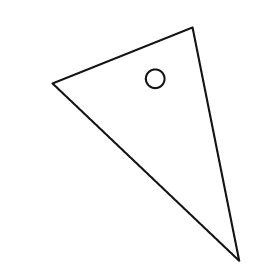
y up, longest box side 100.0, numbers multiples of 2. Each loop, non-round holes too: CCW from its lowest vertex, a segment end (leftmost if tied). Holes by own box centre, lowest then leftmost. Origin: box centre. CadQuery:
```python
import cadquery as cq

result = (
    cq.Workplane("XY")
    .moveTo(40.0, -50.0)
    .lineTo(20.0, 50.0)
    .lineTo(-40.0, 26.0)
    .close()
    .moveTo(4.0, 28.0)
    .circle(4.0)
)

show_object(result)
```